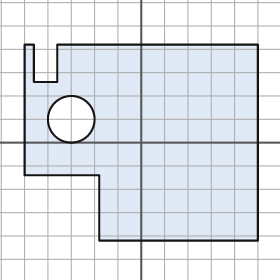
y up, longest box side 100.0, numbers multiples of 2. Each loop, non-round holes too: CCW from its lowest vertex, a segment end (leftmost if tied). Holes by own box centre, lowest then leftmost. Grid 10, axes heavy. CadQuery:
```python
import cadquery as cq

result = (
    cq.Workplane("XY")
    .moveTo(-18.0, -42.0)
    .lineTo(50.0, -42.0)
    .lineTo(50.0, 42.0)
    .lineTo(-36.0, 42.0)
    .lineTo(-36.0, 26.0)
    .lineTo(-46.0, 26.0)
    .lineTo(-46.0, 42.0)
    .lineTo(-50.0, 42.0)
    .lineTo(-50.0, -14.0)
    .lineTo(-18.0, -14.0)
    .close()
    .moveTo(-30.0, 10.0)
    .circle(10.0)
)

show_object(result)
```